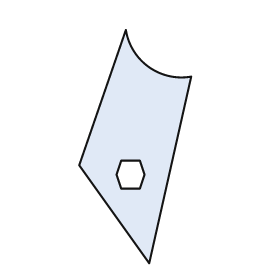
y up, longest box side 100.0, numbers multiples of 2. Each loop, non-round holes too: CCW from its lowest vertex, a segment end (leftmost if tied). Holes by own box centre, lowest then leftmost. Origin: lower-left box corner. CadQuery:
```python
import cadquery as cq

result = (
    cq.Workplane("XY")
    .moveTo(30.0, 0.0)
    .lineTo(48.0, 80.0)
    .threePointArc((30.0, 84.0), (20.0, 100.0))
    .lineTo(0.0, 42.0)
    .close()
    .moveTo(18.0, 32.0)
    .lineTo(26.0, 32.0)
    .lineTo(28.0, 38.0)
    .lineTo(26.0, 44.0)
    .lineTo(18.0, 44.0)
    .lineTo(16.0, 38.0)
    .close()
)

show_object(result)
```